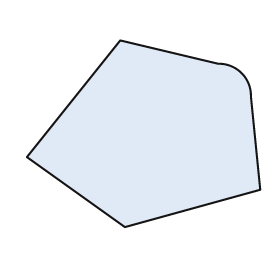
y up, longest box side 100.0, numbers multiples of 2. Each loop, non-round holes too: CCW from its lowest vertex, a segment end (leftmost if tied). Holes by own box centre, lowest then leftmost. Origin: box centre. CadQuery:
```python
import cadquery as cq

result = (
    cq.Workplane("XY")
    .moveTo(-8.0, -40.0)
    .lineTo(50.0, -24.0)
    .lineTo(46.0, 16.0)
    .threePointArc((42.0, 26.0), (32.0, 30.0))
    .lineTo(-10.0, 40.0)
    .lineTo(-50.0, -10.0)
    .close()
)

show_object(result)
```